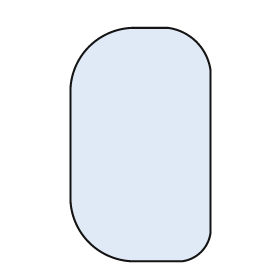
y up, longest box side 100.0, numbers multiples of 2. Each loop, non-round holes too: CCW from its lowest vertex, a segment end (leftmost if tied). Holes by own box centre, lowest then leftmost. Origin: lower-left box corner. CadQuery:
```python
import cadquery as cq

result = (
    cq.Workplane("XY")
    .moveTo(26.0, 0.0)
    .lineTo(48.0, 0.0)
    .threePointArc((56.0, 4.0), (60.0, 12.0))
    .lineTo(60.0, 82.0)
    .threePointArc((54.0, 94.0), (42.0, 100.0))
    .lineTo(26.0, 100.0)
    .threePointArc((8.0, 92.0), (0.0, 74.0))
    .lineTo(0.0, 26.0)
    .threePointArc((8.0, 8.0), (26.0, 0.0))
    .close()
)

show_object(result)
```